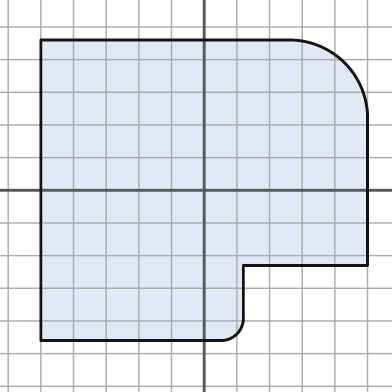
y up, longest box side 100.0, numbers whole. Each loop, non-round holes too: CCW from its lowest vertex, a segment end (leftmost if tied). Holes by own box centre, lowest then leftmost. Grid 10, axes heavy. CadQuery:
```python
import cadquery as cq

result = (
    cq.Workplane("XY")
    .moveTo(-50.0, -46.0)
    .lineTo(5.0, -46.0)
    .threePointArc((10.0, -44.0), (12.0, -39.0))
    .lineTo(12.0, -23.0)
    .lineTo(50.0, -23.0)
    .lineTo(50.0, 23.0)
    .threePointArc((43.0, 39.0), (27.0, 46.0))
    .lineTo(-50.0, 46.0)
    .close()
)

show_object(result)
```